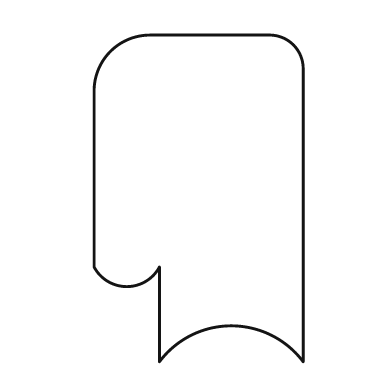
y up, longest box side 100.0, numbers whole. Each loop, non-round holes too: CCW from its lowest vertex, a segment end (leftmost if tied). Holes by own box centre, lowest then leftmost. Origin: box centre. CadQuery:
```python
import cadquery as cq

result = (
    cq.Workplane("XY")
    .moveTo(-12.0, -50.0)
    .threePointArc((10.0, -39.0), (32.0, -50.0))
    .lineTo(32.0, 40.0)
    .threePointArc((29.0, 47.0), (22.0, 50.0))
    .lineTo(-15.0, 50.0)
    .threePointArc((-27.0, 45.0), (-32.0, 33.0))
    .lineTo(-32.0, -21.0)
    .threePointArc((-22.0, -27.0), (-12.0, -21.0))
    .close()
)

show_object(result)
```